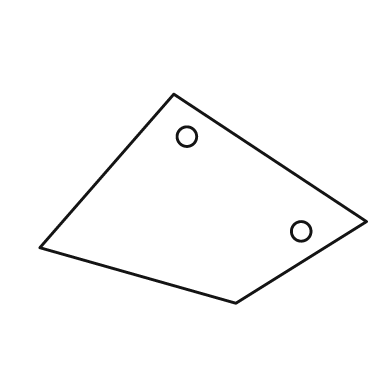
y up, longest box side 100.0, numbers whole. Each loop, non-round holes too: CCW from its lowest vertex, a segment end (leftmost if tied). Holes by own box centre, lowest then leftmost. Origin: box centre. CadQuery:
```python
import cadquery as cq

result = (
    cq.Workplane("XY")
    .moveTo(10.0, -32.0)
    .lineTo(50.0, -7.0)
    .lineTo(-9.0, 32.0)
    .lineTo(-50.0, -15.0)
    .close()
    .moveTo(30.0, -10.0)
    .circle(3.0)
    .moveTo(-5.0, 19.0)
    .circle(3.0)
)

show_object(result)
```